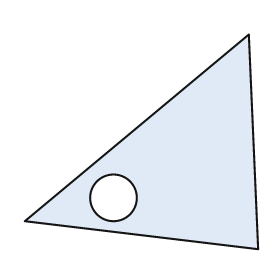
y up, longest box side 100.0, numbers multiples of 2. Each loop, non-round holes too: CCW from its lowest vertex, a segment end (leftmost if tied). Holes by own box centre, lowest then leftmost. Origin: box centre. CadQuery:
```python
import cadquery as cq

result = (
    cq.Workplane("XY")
    .moveTo(50.0, -46.0)
    .lineTo(46.0, 46.0)
    .lineTo(-50.0, -34.0)
    .close()
    .moveTo(-12.0, -24.0)
    .circle(10.0)
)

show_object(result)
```